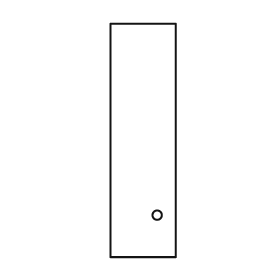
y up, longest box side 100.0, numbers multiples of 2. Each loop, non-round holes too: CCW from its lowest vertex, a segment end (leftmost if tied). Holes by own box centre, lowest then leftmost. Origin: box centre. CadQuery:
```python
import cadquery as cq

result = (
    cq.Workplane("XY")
    .moveTo(-14.0, -50.0)
    .lineTo(14.0, -50.0)
    .lineTo(14.0, 50.0)
    .lineTo(-14.0, 50.0)
    .close()
    .moveTo(6.0, -32.0)
    .circle(2.0)
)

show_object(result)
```